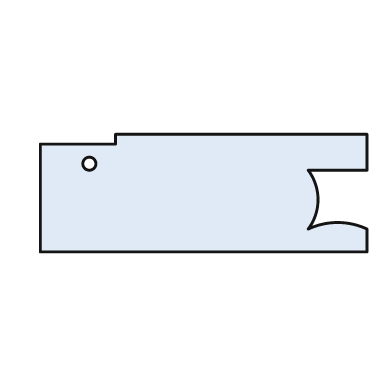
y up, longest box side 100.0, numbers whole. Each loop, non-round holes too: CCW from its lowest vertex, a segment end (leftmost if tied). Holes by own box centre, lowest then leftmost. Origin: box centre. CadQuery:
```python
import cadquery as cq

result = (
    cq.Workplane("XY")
    .moveTo(-50.0, -18.0)
    .lineTo(50.0, -18.0)
    .lineTo(50.0, -11.0)
    .threePointArc((41.0, -9.0), (32.0, -11.0))
    .threePointArc((35.0, -2.0), (32.0, 7.0))
    .lineTo(50.0, 7.0)
    .lineTo(50.0, 18.0)
    .lineTo(-27.0, 18.0)
    .lineTo(-27.0, 15.0)
    .lineTo(-50.0, 15.0)
    .close()
    .moveTo(-35.0, 9.0)
    .circle(2.0)
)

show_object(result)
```